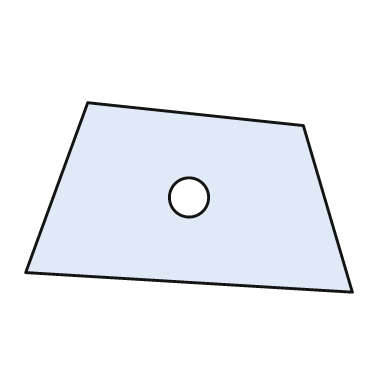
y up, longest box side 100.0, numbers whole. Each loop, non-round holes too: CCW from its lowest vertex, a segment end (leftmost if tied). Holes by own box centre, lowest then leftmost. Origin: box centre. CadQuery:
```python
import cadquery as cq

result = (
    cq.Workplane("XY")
    .moveTo(50.0, -29.0)
    .lineTo(35.0, 22.0)
    .lineTo(-31.0, 29.0)
    .lineTo(-50.0, -23.0)
    .close()
    .moveTo(0.0, 0.0)
    .circle(6.0)
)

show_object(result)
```